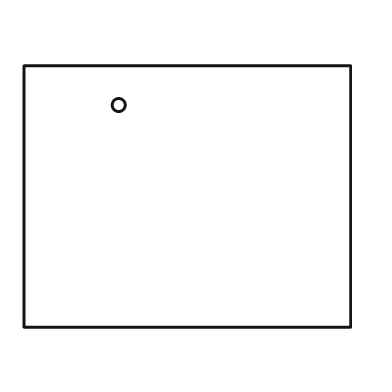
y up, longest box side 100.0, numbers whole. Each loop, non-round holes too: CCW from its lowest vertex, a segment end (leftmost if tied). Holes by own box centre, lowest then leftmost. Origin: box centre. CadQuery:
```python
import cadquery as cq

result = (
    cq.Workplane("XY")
    .moveTo(-50.0, -40.0)
    .lineTo(50.0, -40.0)
    .lineTo(50.0, 40.0)
    .lineTo(-50.0, 40.0)
    .close()
    .moveTo(-21.0, 28.0)
    .circle(2.0)
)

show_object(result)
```